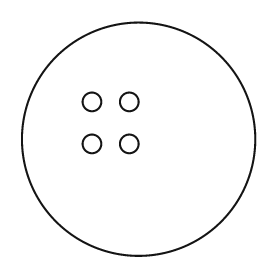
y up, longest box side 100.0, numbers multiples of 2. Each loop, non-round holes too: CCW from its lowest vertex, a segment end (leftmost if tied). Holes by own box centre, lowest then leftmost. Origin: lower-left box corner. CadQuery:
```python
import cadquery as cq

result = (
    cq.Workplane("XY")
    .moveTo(50.0, 50.0)
    .circle(50.0)
    .moveTo(30.0, 48.0)
    .circle(4.0)
    .moveTo(46.0, 48.0)
    .circle(4.0)
    .moveTo(30.0, 66.0)
    .circle(4.0)
    .moveTo(46.0, 66.0)
    .circle(4.0)
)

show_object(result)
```